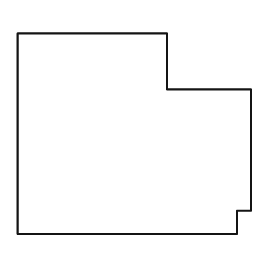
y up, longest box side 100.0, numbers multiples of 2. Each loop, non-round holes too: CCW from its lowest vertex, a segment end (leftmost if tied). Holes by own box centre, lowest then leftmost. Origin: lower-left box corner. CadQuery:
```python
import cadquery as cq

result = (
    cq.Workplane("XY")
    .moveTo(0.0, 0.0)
    .lineTo(94.0, 0.0)
    .lineTo(94.0, 10.0)
    .lineTo(100.0, 10.0)
    .lineTo(100.0, 62.0)
    .lineTo(64.0, 62.0)
    .lineTo(64.0, 86.0)
    .lineTo(0.0, 86.0)
    .close()
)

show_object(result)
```